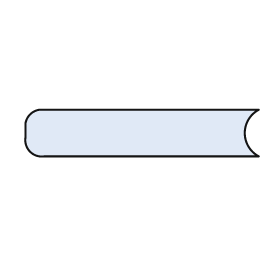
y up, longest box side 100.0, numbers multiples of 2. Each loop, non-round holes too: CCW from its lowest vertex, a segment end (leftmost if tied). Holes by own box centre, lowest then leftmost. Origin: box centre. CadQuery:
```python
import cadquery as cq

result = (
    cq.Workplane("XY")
    .moveTo(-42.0, -10.0)
    .lineTo(50.0, -10.0)
    .threePointArc((44.0, 0.0), (50.0, 10.0))
    .lineTo(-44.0, 10.0)
    .threePointArc((-48.0, 8.0), (-50.0, 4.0))
    .lineTo(-50.0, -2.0)
    .threePointArc((-48.0, -8.0), (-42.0, -10.0))
    .close()
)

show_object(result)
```